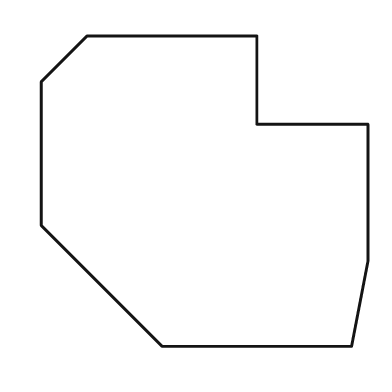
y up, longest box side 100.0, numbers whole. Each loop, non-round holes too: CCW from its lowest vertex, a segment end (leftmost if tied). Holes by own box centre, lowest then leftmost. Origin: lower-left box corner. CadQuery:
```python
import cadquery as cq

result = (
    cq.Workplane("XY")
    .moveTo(37.0, 0.0)
    .lineTo(95.0, 0.0)
    .lineTo(100.0, 26.0)
    .lineTo(100.0, 68.0)
    .lineTo(66.0, 68.0)
    .lineTo(66.0, 95.0)
    .lineTo(14.0, 95.0)
    .lineTo(0.0, 81.0)
    .lineTo(0.0, 37.0)
    .close()
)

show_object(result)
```